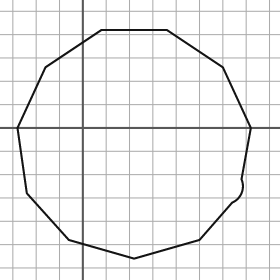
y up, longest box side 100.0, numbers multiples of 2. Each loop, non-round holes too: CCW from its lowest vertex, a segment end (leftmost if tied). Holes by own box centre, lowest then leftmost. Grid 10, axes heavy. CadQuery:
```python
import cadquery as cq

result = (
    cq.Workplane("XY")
    .moveTo(22.0, -56.0)
    .lineTo(50.0, -48.0)
    .lineTo(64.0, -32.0)
    .threePointArc((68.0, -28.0), (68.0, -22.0))
    .lineTo(72.0, 0.0)
    .lineTo(60.0, 26.0)
    .lineTo(36.0, 42.0)
    .lineTo(8.0, 42.0)
    .lineTo(-16.0, 26.0)
    .lineTo(-28.0, 0.0)
    .lineTo(-24.0, -28.0)
    .lineTo(-6.0, -48.0)
    .close()
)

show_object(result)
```